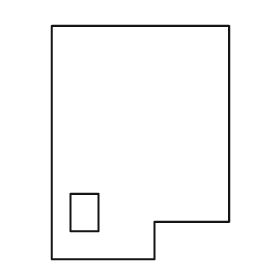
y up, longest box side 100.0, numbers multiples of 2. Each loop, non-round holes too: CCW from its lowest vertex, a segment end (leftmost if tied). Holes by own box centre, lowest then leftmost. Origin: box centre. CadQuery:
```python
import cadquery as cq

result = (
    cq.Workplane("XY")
    .moveTo(-38.0, -50.0)
    .lineTo(6.0, -50.0)
    .lineTo(6.0, -34.0)
    .lineTo(38.0, -34.0)
    .lineTo(38.0, 50.0)
    .lineTo(-38.0, 50.0)
    .close()
    .moveTo(-30.0, -38.0)
    .lineTo(-18.0, -38.0)
    .lineTo(-18.0, -22.0)
    .lineTo(-30.0, -22.0)
    .close()
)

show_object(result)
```